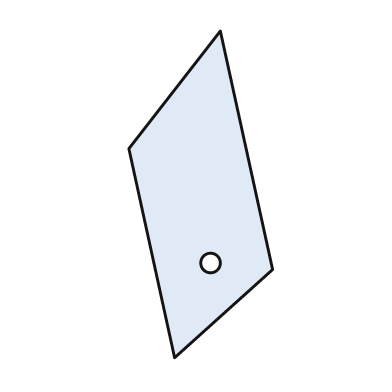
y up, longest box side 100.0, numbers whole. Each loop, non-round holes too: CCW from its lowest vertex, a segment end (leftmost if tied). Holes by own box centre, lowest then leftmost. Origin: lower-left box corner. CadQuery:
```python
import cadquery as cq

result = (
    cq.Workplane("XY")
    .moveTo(14.0, 0.0)
    .lineTo(44.0, 27.0)
    .lineTo(28.0, 100.0)
    .lineTo(0.0, 64.0)
    .close()
    .moveTo(25.0, 29.0)
    .circle(3.0)
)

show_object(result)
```